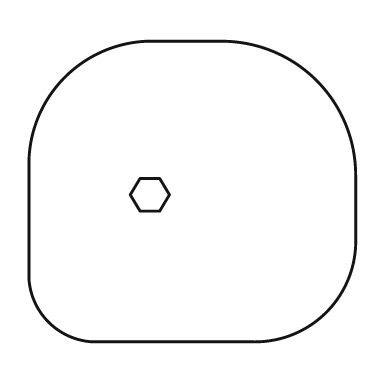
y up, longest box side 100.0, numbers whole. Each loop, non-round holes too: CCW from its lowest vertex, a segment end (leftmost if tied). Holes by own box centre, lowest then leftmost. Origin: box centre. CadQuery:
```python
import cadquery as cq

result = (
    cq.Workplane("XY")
    .moveTo(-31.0, -46.0)
    .lineTo(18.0, -46.0)
    .threePointArc((41.0, -37.0), (50.0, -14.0))
    .lineTo(50.0, 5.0)
    .threePointArc((38.0, 34.0), (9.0, 46.0))
    .lineTo(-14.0, 46.0)
    .threePointArc((-39.0, 35.0), (-50.0, 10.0))
    .lineTo(-50.0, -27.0)
    .threePointArc((-44.0, -40.0), (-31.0, -46.0))
    .close()
    .moveTo(-16.0, -6.0)
    .lineTo(-10.0, -6.0)
    .lineTo(-7.0, -1.0)
    .lineTo(-10.0, 4.0)
    .lineTo(-16.0, 4.0)
    .lineTo(-19.0, -1.0)
    .close()
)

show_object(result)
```